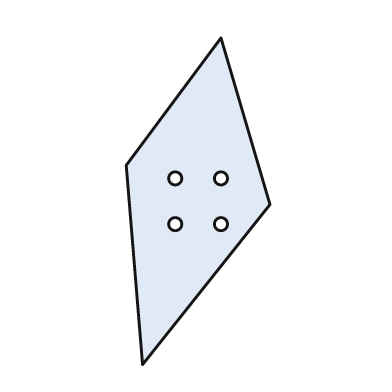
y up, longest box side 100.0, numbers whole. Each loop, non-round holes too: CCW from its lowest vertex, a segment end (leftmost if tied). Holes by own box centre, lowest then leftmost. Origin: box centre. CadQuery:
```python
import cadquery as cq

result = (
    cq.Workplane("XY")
    .moveTo(-17.0, -50.0)
    .lineTo(22.0, -1.0)
    .lineTo(7.0, 50.0)
    .lineTo(-22.0, 11.0)
    .close()
    .moveTo(-7.0, -7.0)
    .circle(2.0)
    .moveTo(7.0, -7.0)
    .circle(2.0)
    .moveTo(-7.0, 7.0)
    .circle(2.0)
    .moveTo(7.0, 7.0)
    .circle(2.0)
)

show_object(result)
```